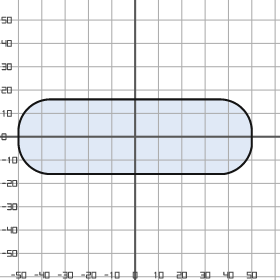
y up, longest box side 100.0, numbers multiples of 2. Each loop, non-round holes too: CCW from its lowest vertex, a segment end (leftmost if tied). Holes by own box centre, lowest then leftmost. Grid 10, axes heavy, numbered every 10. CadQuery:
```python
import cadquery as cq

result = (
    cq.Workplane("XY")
    .moveTo(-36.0, -16.0)
    .lineTo(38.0, -16.0)
    .threePointArc((46.0, -12.0), (50.0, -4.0))
    .lineTo(50.0, 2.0)
    .threePointArc((46.0, 12.0), (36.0, 16.0))
    .lineTo(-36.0, 16.0)
    .threePointArc((-46.0, 12.0), (-50.0, 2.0))
    .lineTo(-50.0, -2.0)
    .threePointArc((-46.0, -12.0), (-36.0, -16.0))
    .close()
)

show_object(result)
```